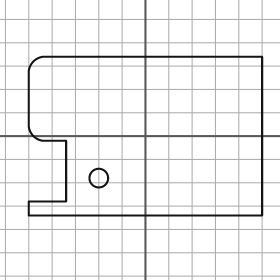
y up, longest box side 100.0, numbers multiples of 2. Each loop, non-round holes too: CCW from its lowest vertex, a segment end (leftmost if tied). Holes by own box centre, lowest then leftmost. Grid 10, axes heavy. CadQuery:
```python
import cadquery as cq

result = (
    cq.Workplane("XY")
    .moveTo(-50.0, -34.0)
    .lineTo(50.0, -34.0)
    .lineTo(50.0, 34.0)
    .lineTo(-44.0, 34.0)
    .threePointArc((-48.0, 32.0), (-50.0, 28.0))
    .lineTo(-50.0, 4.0)
    .threePointArc((-48.0, 0.0), (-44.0, -2.0))
    .lineTo(-34.0, -2.0)
    .lineTo(-34.0, -28.0)
    .lineTo(-50.0, -28.0)
    .close()
    .moveTo(-20.0, -18.0)
    .circle(4.0)
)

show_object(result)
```